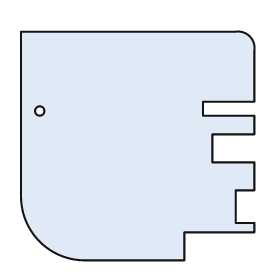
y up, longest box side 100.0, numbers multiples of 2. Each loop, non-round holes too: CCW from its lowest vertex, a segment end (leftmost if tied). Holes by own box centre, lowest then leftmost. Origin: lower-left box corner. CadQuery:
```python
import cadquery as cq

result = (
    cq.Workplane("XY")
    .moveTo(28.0, 0.0)
    .lineTo(70.0, 0.0)
    .lineTo(70.0, 12.0)
    .lineTo(100.0, 12.0)
    .lineTo(100.0, 16.0)
    .lineTo(92.0, 16.0)
    .lineTo(92.0, 30.0)
    .lineTo(100.0, 30.0)
    .lineTo(100.0, 42.0)
    .lineTo(82.0, 42.0)
    .lineTo(82.0, 54.0)
    .lineTo(100.0, 54.0)
    .lineTo(100.0, 62.0)
    .lineTo(78.0, 62.0)
    .lineTo(78.0, 68.0)
    .lineTo(100.0, 68.0)
    .lineTo(100.0, 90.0)
    .threePointArc((98.0, 96.0), (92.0, 98.0))
    .lineTo(0.0, 98.0)
    .lineTo(0.0, 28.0)
    .threePointArc((8.0, 8.0), (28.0, 0.0))
    .close()
    .moveTo(8.0, 64.0)
    .circle(2.0)
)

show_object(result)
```